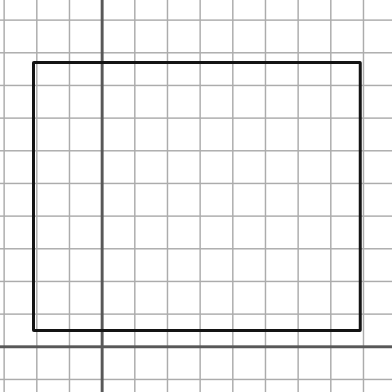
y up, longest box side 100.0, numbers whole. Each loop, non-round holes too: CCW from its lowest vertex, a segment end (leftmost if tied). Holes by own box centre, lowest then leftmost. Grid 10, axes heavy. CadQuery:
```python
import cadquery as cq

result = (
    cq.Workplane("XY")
    .moveTo(-21.0, 5.0)
    .lineTo(79.0, 5.0)
    .lineTo(79.0, 87.0)
    .lineTo(-21.0, 87.0)
    .close()
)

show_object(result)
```